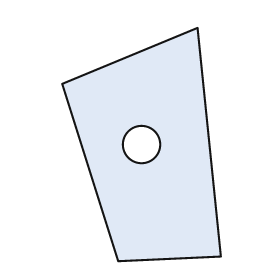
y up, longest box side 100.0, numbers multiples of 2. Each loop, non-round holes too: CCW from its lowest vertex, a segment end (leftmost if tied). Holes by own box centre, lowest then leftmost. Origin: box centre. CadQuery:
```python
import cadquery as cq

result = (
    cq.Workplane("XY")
    .moveTo(-10.0, -50.0)
    .lineTo(34.0, -48.0)
    .lineTo(24.0, 50.0)
    .lineTo(-34.0, 26.0)
    .close()
    .moveTo(0.0, 0.0)
    .circle(8.0)
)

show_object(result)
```